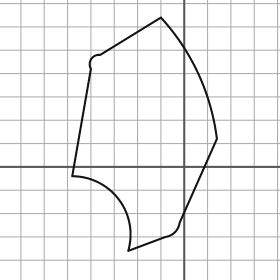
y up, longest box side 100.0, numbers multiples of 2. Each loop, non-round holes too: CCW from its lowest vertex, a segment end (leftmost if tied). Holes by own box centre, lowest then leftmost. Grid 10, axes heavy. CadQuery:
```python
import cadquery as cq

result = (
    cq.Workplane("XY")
    .moveTo(-24.0, -36.0)
    .lineTo(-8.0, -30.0)
    .threePointArc((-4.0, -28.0), (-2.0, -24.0))
    .lineTo(14.0, 12.0)
    .threePointArc((6.0, 40.0), (-10.0, 64.0))
    .lineTo(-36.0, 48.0)
    .threePointArc((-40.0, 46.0), (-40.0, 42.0))
    .lineTo(-48.0, -4.0)
    .threePointArc((-28.0, -14.0), (-24.0, -36.0))
    .close()
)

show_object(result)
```